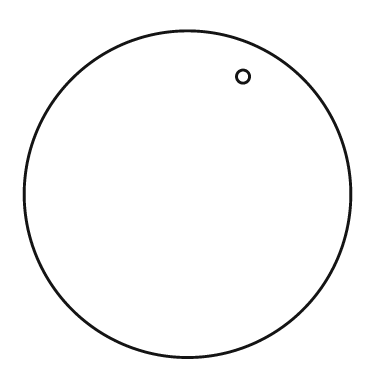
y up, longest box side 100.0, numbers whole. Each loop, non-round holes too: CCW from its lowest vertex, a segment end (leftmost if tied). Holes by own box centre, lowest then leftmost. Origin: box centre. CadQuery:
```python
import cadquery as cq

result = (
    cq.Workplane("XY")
    .moveTo(0.0, 0.0)
    .circle(50.0)
    .moveTo(17.0, 36.0)
    .circle(2.0)
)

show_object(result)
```